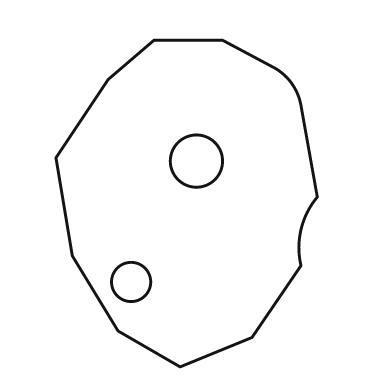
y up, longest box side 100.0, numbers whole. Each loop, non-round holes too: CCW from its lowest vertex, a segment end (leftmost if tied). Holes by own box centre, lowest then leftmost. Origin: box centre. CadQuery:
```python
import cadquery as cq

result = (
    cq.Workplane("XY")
    .moveTo(-2.0, -50.0)
    .lineTo(20.0, -41.0)
    .lineTo(35.0, -19.0)
    .threePointArc((35.0, -8.0), (40.0, 2.0))
    .lineTo(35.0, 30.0)
    .threePointArc((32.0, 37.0), (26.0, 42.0))
    .lineTo(11.0, 50.0)
    .lineTo(-10.0, 50.0)
    .lineTo(-24.0, 38.0)
    .lineTo(-40.0, 14.0)
    .lineTo(-35.0, -16.0)
    .lineTo(-21.0, -39.0)
    .close()
    .moveTo(-17.0, -24.0)
    .circle(6.0)
    .moveTo(3.0, 13.0)
    .circle(8.0)
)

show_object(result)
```